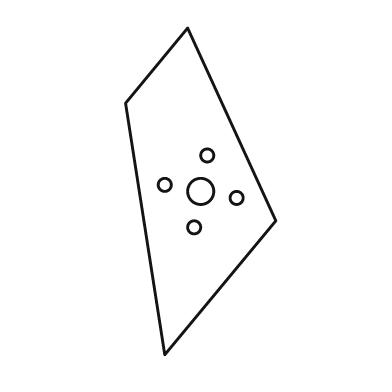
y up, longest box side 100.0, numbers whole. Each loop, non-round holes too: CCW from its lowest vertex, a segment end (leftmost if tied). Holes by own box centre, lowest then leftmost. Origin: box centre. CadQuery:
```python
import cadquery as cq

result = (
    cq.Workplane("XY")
    .moveTo(-11.0, -50.0)
    .lineTo(23.0, -9.0)
    .lineTo(-4.0, 50.0)
    .lineTo(-23.0, 27.0)
    .close()
    .moveTo(-2.0, -11.0)
    .circle(2.0)
    .moveTo(11.0, -2.0)
    .circle(2.0)
    .moveTo(0.0, 0.0)
    .circle(4.0)
    .moveTo(-11.0, 2.0)
    .circle(2.0)
    .moveTo(2.0, 11.0)
    .circle(2.0)
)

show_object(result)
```